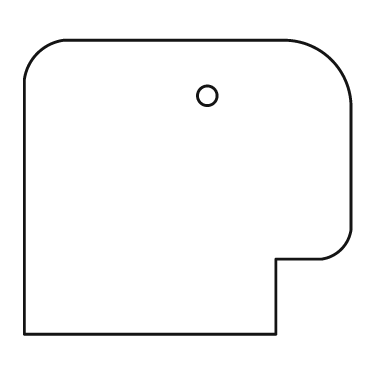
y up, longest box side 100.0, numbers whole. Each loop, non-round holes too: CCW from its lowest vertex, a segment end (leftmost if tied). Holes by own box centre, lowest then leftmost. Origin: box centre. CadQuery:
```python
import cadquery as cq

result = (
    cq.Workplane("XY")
    .moveTo(-50.0, -45.0)
    .lineTo(27.0, -45.0)
    .lineTo(27.0, -22.0)
    .lineTo(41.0, -22.0)
    .threePointArc((47.0, -19.0), (50.0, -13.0))
    .lineTo(50.0, 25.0)
    .threePointArc((44.0, 39.0), (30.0, 45.0))
    .lineTo(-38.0, 45.0)
    .threePointArc((-46.0, 41.0), (-50.0, 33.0))
    .close()
    .moveTo(6.0, 28.0)
    .circle(3.0)
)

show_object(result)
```